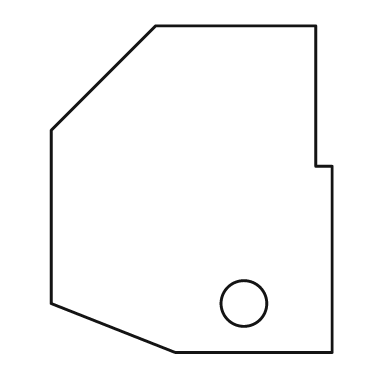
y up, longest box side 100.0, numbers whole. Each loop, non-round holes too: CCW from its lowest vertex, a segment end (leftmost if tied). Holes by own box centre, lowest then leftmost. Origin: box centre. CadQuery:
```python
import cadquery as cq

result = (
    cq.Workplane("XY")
    .moveTo(-5.0, -50.0)
    .lineTo(43.0, -50.0)
    .lineTo(43.0, 7.0)
    .lineTo(38.0, 7.0)
    .lineTo(38.0, 50.0)
    .lineTo(-11.0, 50.0)
    .lineTo(-43.0, 18.0)
    .lineTo(-43.0, -35.0)
    .close()
    .moveTo(16.0, -35.0)
    .circle(7.0)
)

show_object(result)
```